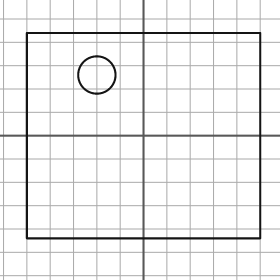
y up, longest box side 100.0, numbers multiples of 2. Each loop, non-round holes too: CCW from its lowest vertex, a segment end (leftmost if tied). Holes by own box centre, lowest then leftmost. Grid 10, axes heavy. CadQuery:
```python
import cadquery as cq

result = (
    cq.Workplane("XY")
    .moveTo(-50.0, -44.0)
    .lineTo(50.0, -44.0)
    .lineTo(50.0, 44.0)
    .lineTo(-50.0, 44.0)
    .close()
    .moveTo(-20.0, 26.0)
    .circle(8.0)
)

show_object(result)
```